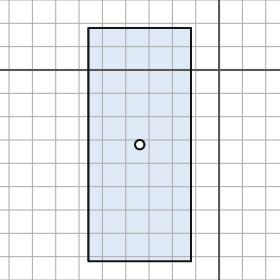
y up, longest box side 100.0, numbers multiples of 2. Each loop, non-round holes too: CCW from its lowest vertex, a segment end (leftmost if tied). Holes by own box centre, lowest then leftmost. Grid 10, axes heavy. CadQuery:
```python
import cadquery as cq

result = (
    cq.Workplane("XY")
    .moveTo(-56.0, -82.0)
    .lineTo(-12.0, -82.0)
    .lineTo(-12.0, 18.0)
    .lineTo(-56.0, 18.0)
    .close()
    .moveTo(-34.0, -32.0)
    .circle(2.0)
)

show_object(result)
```